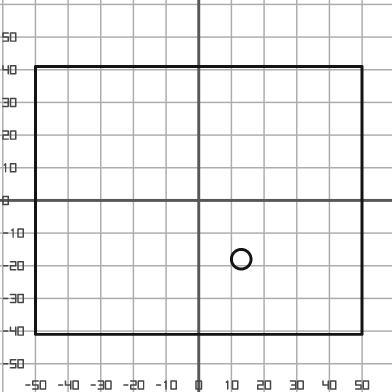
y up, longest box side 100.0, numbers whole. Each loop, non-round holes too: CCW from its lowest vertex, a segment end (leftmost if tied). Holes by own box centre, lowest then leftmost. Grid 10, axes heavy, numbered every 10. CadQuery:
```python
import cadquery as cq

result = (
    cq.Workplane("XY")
    .moveTo(-50.0, -41.0)
    .lineTo(50.0, -41.0)
    .lineTo(50.0, 41.0)
    .lineTo(-50.0, 41.0)
    .close()
    .moveTo(13.0, -18.0)
    .circle(3.0)
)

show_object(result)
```